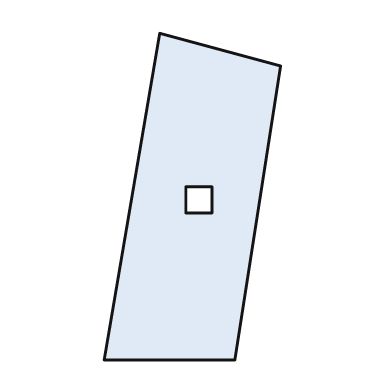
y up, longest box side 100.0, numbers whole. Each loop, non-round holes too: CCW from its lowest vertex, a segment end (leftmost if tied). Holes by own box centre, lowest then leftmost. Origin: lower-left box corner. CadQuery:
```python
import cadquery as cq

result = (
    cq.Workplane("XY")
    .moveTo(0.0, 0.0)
    .lineTo(40.0, 0.0)
    .lineTo(54.0, 90.0)
    .lineTo(17.0, 100.0)
    .close()
    .moveTo(25.0, 45.0)
    .lineTo(33.0, 45.0)
    .lineTo(33.0, 53.0)
    .lineTo(25.0, 53.0)
    .close()
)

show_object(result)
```